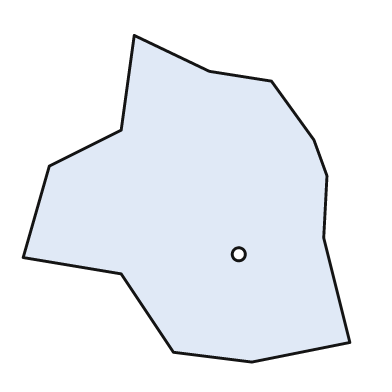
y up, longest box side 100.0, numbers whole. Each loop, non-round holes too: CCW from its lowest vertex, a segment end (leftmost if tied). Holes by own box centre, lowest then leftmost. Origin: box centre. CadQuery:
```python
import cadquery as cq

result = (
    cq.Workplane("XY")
    .moveTo(20.0, -50.0)
    .lineTo(50.0, -44.0)
    .lineTo(42.0, -12.0)
    .lineTo(43.0, 7.0)
    .lineTo(39.0, 18.0)
    .lineTo(26.0, 36.0)
    .lineTo(7.0, 39.0)
    .lineTo(-16.0, 50.0)
    .lineTo(-20.0, 21.0)
    .lineTo(-42.0, 10.0)
    .lineTo(-50.0, -18.0)
    .lineTo(-20.0, -23.0)
    .lineTo(-4.0, -47.0)
    .close()
    .moveTo(16.0, -17.0)
    .circle(2.0)
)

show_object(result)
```